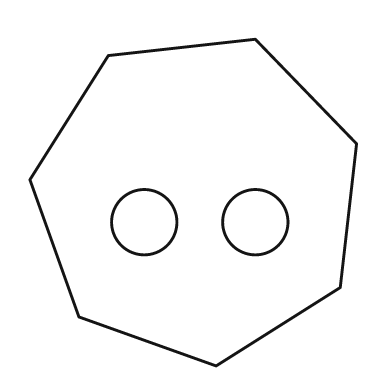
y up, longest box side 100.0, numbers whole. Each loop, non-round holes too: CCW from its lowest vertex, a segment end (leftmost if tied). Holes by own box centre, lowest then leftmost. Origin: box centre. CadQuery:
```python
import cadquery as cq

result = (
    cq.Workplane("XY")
    .moveTo(7.0, -50.0)
    .lineTo(45.0, -26.0)
    .lineTo(50.0, 18.0)
    .lineTo(19.0, 50.0)
    .lineTo(-26.0, 45.0)
    .lineTo(-50.0, 7.0)
    .lineTo(-35.0, -35.0)
    .close()
    .moveTo(-15.0, -6.0)
    .circle(10.0)
    .moveTo(19.0, -6.0)
    .circle(10.0)
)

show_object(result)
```